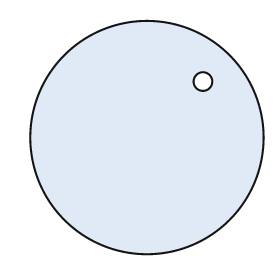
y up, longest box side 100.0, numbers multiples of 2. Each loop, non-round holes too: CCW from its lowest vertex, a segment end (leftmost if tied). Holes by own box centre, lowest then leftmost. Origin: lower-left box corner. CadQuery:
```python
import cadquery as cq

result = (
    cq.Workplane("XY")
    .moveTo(50.0, 50.0)
    .circle(50.0)
    .moveTo(74.0, 74.0)
    .circle(4.0)
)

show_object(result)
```